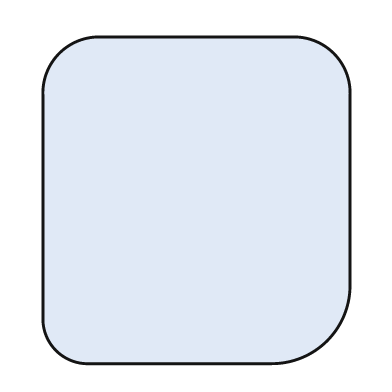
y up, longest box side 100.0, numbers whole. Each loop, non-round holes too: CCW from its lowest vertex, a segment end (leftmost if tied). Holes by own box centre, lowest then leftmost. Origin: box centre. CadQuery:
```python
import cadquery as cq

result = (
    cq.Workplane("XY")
    .moveTo(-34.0, -50.0)
    .lineTo(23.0, -50.0)
    .threePointArc((40.0, -43.0), (47.0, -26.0))
    .lineTo(47.0, 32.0)
    .threePointArc((42.0, 45.0), (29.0, 50.0))
    .lineTo(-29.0, 50.0)
    .threePointArc((-42.0, 45.0), (-47.0, 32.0))
    .lineTo(-47.0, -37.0)
    .threePointArc((-43.0, -46.0), (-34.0, -50.0))
    .close()
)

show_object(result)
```